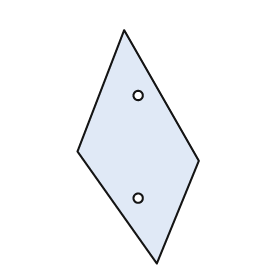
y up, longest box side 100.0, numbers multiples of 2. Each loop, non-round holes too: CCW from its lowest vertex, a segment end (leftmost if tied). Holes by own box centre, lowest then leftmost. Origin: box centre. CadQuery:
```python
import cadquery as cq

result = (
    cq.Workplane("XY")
    .moveTo(8.0, -50.0)
    .lineTo(26.0, -6.0)
    .lineTo(-6.0, 50.0)
    .lineTo(-26.0, -2.0)
    .close()
    .moveTo(0.0, -22.0)
    .circle(2.0)
    .moveTo(0.0, 22.0)
    .circle(2.0)
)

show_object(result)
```